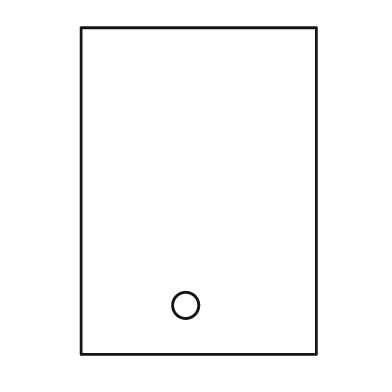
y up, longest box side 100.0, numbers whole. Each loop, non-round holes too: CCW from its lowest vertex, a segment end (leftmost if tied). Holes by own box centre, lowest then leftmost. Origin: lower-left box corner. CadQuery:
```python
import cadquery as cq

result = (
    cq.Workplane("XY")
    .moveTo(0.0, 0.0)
    .lineTo(72.0, 0.0)
    .lineTo(72.0, 100.0)
    .lineTo(0.0, 100.0)
    .close()
    .moveTo(32.0, 15.0)
    .circle(4.0)
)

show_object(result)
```